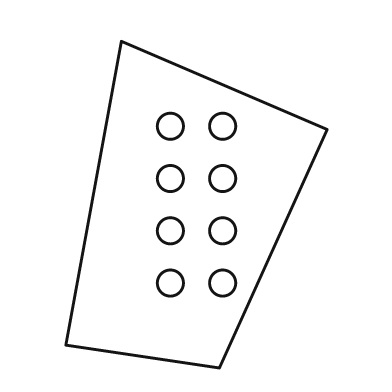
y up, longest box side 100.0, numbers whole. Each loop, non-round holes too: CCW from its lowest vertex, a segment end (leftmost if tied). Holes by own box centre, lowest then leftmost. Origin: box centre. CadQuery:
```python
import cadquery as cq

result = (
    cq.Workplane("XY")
    .moveTo(7.0, -50.0)
    .lineTo(40.0, 23.0)
    .lineTo(-23.0, 50.0)
    .lineTo(-40.0, -43.0)
    .close()
    .moveTo(-8.0, -24.0)
    .circle(4.0)
    .moveTo(8.0, -24.0)
    .circle(4.0)
    .moveTo(-8.0, -8.0)
    .circle(4.0)
    .moveTo(8.0, -8.0)
    .circle(4.0)
    .moveTo(-8.0, 8.0)
    .circle(4.0)
    .moveTo(8.0, 8.0)
    .circle(4.0)
    .moveTo(-8.0, 24.0)
    .circle(4.0)
    .moveTo(8.0, 24.0)
    .circle(4.0)
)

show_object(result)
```